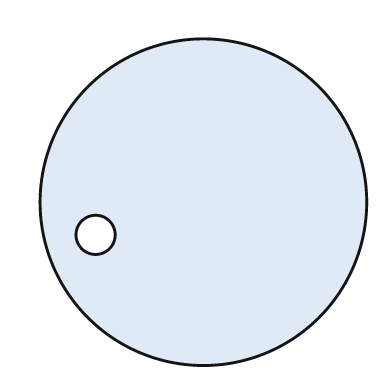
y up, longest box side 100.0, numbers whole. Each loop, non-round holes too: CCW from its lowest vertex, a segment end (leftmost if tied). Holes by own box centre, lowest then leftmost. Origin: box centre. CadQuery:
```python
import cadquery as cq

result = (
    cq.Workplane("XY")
    .moveTo(0.0, 0.0)
    .circle(50.0)
    .moveTo(-33.0, -10.0)
    .circle(6.0)
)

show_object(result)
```